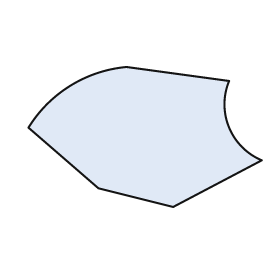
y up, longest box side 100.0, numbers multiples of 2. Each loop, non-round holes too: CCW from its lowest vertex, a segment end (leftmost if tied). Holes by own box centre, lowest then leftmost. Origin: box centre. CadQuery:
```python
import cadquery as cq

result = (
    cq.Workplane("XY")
    .moveTo(12.0, -30.0)
    .lineTo(50.0, -10.0)
    .threePointArc((36.0, 4.0), (36.0, 24.0))
    .lineTo(-8.0, 30.0)
    .threePointArc((-32.0, 22.0), (-50.0, 4.0))
    .lineTo(-20.0, -22.0)
    .close()
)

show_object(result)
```